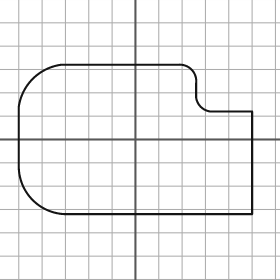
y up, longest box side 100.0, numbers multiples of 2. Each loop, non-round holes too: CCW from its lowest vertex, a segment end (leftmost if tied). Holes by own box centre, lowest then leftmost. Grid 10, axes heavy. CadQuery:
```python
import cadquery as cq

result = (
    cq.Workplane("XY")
    .moveTo(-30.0, -32.0)
    .lineTo(50.0, -32.0)
    .lineTo(50.0, 12.0)
    .lineTo(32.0, 12.0)
    .threePointArc((28.0, 14.0), (26.0, 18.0))
    .lineTo(26.0, 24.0)
    .threePointArc((24.0, 30.0), (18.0, 32.0))
    .lineTo(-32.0, 32.0)
    .threePointArc((-44.0, 26.0), (-50.0, 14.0))
    .lineTo(-50.0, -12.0)
    .threePointArc((-44.0, -26.0), (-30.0, -32.0))
    .close()
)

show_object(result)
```